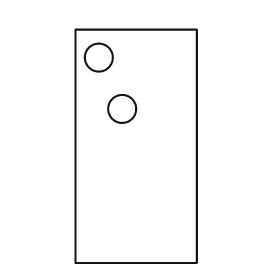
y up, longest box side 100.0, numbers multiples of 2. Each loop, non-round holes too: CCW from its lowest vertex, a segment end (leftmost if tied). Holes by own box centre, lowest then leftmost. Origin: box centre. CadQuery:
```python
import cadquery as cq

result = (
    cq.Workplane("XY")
    .moveTo(-26.0, -50.0)
    .lineTo(26.0, -50.0)
    .lineTo(26.0, 50.0)
    .lineTo(-26.0, 50.0)
    .close()
    .moveTo(-6.0, 16.0)
    .circle(6.0)
    .moveTo(-16.0, 38.0)
    .circle(6.0)
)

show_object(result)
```